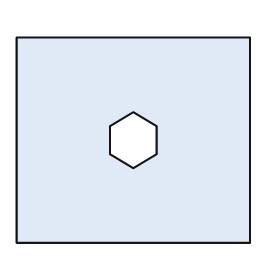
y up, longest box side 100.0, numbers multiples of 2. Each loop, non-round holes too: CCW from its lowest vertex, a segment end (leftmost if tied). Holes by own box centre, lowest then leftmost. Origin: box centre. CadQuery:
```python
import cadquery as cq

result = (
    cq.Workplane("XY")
    .moveTo(-50.0, -44.0)
    .lineTo(50.0, -44.0)
    .lineTo(50.0, 44.0)
    .lineTo(-50.0, 44.0)
    .close()
    .moveTo(0.0, -12.0)
    .lineTo(10.0, -6.0)
    .lineTo(10.0, 6.0)
    .lineTo(0.0, 12.0)
    .lineTo(-10.0, 6.0)
    .lineTo(-10.0, -6.0)
    .close()
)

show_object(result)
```